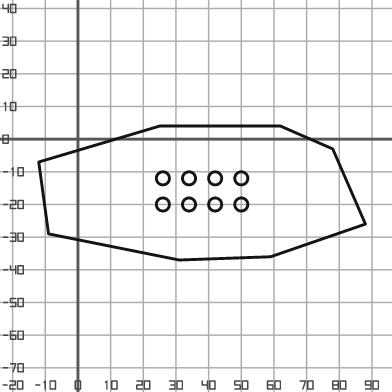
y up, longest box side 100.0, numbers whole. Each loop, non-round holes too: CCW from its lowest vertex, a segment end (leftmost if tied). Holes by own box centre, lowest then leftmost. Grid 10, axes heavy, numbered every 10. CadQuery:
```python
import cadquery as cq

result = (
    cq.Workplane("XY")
    .moveTo(31.0, -37.0)
    .lineTo(59.0, -36.0)
    .lineTo(88.0, -26.0)
    .lineTo(78.0, -3.0)
    .lineTo(62.0, 4.0)
    .lineTo(25.0, 4.0)
    .lineTo(-12.0, -7.0)
    .lineTo(-9.0, -29.0)
    .close()
    .moveTo(26.0, -20.0)
    .circle(2.0)
    .moveTo(34.0, -20.0)
    .circle(2.0)
    .moveTo(42.0, -20.0)
    .circle(2.0)
    .moveTo(50.0, -20.0)
    .circle(2.0)
    .moveTo(26.0, -12.0)
    .circle(2.0)
    .moveTo(34.0, -12.0)
    .circle(2.0)
    .moveTo(42.0, -12.0)
    .circle(2.0)
    .moveTo(50.0, -12.0)
    .circle(2.0)
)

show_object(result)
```